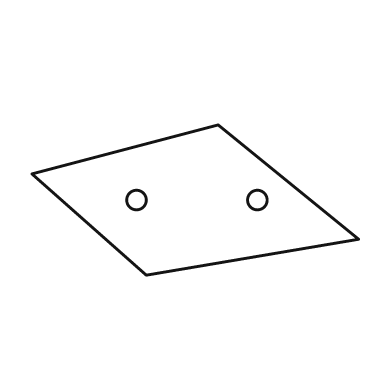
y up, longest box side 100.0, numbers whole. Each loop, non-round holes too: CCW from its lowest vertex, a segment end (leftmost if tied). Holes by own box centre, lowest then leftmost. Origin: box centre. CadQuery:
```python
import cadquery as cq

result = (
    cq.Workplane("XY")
    .moveTo(-15.0, -23.0)
    .lineTo(50.0, -12.0)
    .lineTo(7.0, 23.0)
    .lineTo(-50.0, 8.0)
    .close()
    .moveTo(-18.0, 0.0)
    .circle(3.0)
    .moveTo(19.0, 0.0)
    .circle(3.0)
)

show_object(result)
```